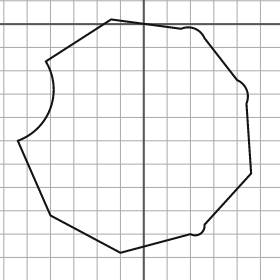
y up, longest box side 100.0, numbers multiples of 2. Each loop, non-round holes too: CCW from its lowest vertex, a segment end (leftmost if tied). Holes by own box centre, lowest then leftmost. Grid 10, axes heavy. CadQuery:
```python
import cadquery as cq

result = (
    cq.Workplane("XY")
    .moveTo(-10.0, -98.0)
    .lineTo(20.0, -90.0)
    .threePointArc((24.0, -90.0), (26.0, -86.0))
    .lineTo(46.0, -64.0)
    .lineTo(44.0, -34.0)
    .threePointArc((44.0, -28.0), (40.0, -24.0))
    .lineTo(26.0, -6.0)
    .threePointArc((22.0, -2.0), (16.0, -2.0))
    .lineTo(-14.0, 2.0)
    .lineTo(-42.0, -16.0)
    .threePointArc((-40.0, -36.0), (-54.0, -50.0))
    .lineTo(-40.0, -82.0)
    .close()
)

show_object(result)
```